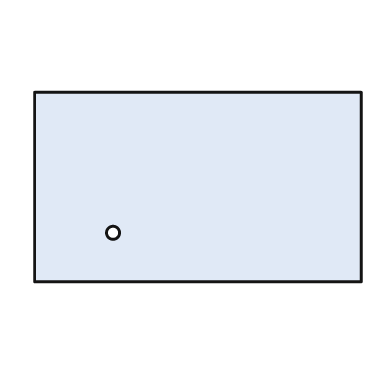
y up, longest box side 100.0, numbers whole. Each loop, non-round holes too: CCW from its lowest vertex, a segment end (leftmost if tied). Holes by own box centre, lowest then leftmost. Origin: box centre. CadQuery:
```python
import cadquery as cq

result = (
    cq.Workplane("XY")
    .moveTo(-50.0, -29.0)
    .lineTo(50.0, -29.0)
    .lineTo(50.0, 29.0)
    .lineTo(-50.0, 29.0)
    .close()
    .moveTo(-26.0, -14.0)
    .circle(2.0)
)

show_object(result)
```